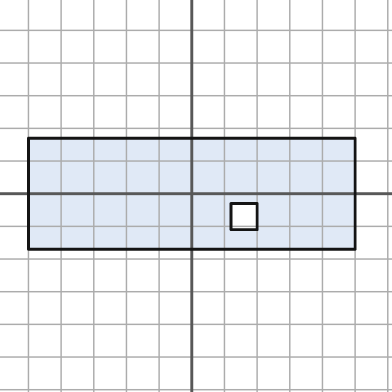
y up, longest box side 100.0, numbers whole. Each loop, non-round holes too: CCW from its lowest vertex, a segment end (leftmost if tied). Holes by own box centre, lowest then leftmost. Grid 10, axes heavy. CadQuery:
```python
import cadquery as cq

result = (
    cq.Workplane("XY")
    .moveTo(-50.0, -17.0)
    .lineTo(50.0, -17.0)
    .lineTo(50.0, 17.0)
    .lineTo(-50.0, 17.0)
    .close()
    .moveTo(12.0, -11.0)
    .lineTo(20.0, -11.0)
    .lineTo(20.0, -3.0)
    .lineTo(12.0, -3.0)
    .close()
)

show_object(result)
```